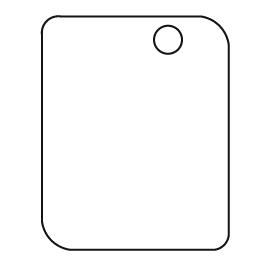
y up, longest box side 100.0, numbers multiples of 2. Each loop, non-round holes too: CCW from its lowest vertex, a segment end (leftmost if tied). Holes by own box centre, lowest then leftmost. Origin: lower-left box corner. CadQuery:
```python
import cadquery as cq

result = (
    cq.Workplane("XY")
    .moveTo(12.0, 0.0)
    .lineTo(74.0, 0.0)
    .threePointArc((78.0, 2.0), (80.0, 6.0))
    .lineTo(80.0, 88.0)
    .threePointArc((76.0, 96.0), (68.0, 100.0))
    .lineTo(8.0, 100.0)
    .threePointArc((2.0, 98.0), (0.0, 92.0))
    .lineTo(0.0, 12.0)
    .threePointArc((4.0, 4.0), (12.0, 0.0))
    .close()
    .moveTo(54.0, 90.0)
    .circle(6.0)
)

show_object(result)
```